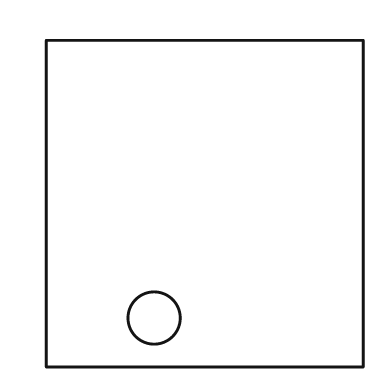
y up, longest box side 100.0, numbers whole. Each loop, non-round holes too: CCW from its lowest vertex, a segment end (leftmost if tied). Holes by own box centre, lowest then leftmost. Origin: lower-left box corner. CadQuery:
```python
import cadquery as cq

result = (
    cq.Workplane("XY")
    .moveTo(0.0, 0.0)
    .lineTo(97.0, 0.0)
    .lineTo(97.0, 100.0)
    .lineTo(0.0, 100.0)
    .close()
    .moveTo(33.0, 15.0)
    .circle(8.0)
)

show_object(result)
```